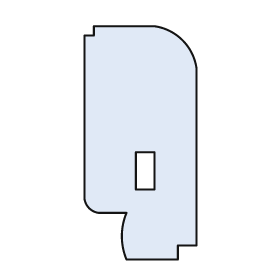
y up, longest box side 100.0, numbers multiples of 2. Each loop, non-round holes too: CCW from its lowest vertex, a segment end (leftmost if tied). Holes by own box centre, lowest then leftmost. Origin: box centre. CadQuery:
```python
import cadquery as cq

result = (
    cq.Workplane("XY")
    .moveTo(-6.0, -50.0)
    .lineTo(16.0, -50.0)
    .lineTo(16.0, -44.0)
    .lineTo(24.0, -44.0)
    .lineTo(24.0, 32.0)
    .threePointArc((18.0, 44.0), (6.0, 50.0))
    .lineTo(-20.0, 50.0)
    .lineTo(-20.0, 46.0)
    .lineTo(-24.0, 46.0)
    .lineTo(-24.0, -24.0)
    .threePointArc((-22.0, -28.0), (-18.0, -30.0))
    .lineTo(-6.0, -30.0)
    .threePointArc((-8.0, -40.0), (-6.0, -50.0))
    .close()
    .moveTo(-2.0, -20.0)
    .lineTo(6.0, -20.0)
    .lineTo(6.0, -4.0)
    .lineTo(-2.0, -4.0)
    .close()
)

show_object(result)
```